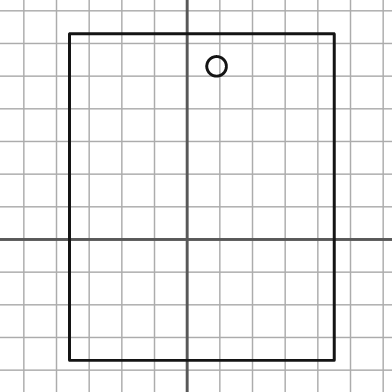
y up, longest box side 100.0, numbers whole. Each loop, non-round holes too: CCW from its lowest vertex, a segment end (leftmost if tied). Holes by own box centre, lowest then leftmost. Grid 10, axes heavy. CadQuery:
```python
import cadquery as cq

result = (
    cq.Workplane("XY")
    .moveTo(-36.0, -37.0)
    .lineTo(45.0, -37.0)
    .lineTo(45.0, 63.0)
    .lineTo(-36.0, 63.0)
    .close()
    .moveTo(9.0, 53.0)
    .circle(3.0)
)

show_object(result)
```